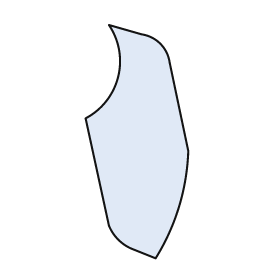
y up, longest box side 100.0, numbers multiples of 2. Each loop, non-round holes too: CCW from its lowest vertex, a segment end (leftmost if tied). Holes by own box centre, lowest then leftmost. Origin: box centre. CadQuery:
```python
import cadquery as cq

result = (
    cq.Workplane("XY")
    .moveTo(8.0, -50.0)
    .threePointArc((18.0, -28.0), (22.0, -4.0))
    .lineTo(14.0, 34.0)
    .threePointArc((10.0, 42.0), (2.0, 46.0))
    .lineTo(-12.0, 50.0)
    .threePointArc((-8.0, 28.0), (-22.0, 10.0))
    .lineTo(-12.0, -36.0)
    .threePointArc((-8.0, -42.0), (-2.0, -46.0))
    .close()
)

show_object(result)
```